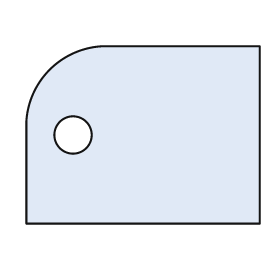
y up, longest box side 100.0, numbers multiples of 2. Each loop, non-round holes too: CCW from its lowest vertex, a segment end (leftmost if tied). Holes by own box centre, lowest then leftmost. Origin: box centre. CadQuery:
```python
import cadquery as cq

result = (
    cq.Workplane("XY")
    .moveTo(-50.0, -38.0)
    .lineTo(50.0, -38.0)
    .lineTo(50.0, 38.0)
    .lineTo(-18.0, 38.0)
    .threePointArc((-40.0, 28.0), (-50.0, 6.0))
    .close()
    .moveTo(-30.0, 0.0)
    .circle(8.0)
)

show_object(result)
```